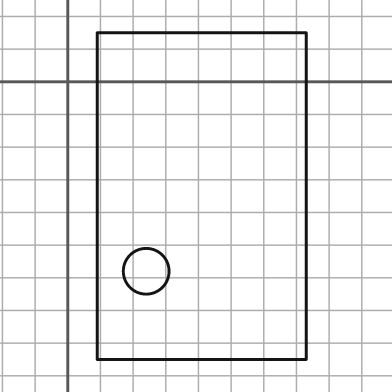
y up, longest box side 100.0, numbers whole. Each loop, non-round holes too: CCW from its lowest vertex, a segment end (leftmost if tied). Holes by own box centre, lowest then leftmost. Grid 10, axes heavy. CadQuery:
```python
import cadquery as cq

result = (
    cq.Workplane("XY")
    .moveTo(9.0, -85.0)
    .lineTo(73.0, -85.0)
    .lineTo(73.0, 15.0)
    .lineTo(9.0, 15.0)
    .close()
    .moveTo(24.0, -58.0)
    .circle(7.0)
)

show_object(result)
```